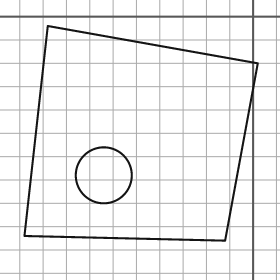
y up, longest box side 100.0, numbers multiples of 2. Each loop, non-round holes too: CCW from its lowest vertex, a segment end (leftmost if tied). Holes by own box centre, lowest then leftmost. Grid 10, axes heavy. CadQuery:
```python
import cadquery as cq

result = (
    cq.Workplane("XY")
    .moveTo(-12.0, -96.0)
    .lineTo(2.0, -20.0)
    .lineTo(-88.0, -4.0)
    .lineTo(-98.0, -94.0)
    .close()
    .moveTo(-64.0, -68.0)
    .circle(12.0)
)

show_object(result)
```